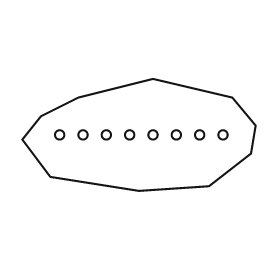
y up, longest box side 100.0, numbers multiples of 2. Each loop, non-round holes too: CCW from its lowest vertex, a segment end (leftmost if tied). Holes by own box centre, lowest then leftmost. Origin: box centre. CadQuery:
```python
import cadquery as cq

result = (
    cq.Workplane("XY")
    .moveTo(0.0, -24.0)
    .lineTo(30.0, -22.0)
    .lineTo(48.0, -8.0)
    .lineTo(50.0, 4.0)
    .lineTo(40.0, 16.0)
    .lineTo(6.0, 24.0)
    .lineTo(-26.0, 16.0)
    .lineTo(-42.0, 8.0)
    .lineTo(-50.0, -2.0)
    .lineTo(-38.0, -18.0)
    .close()
    .moveTo(-34.0, 0.0)
    .circle(2.0)
    .moveTo(-24.0, 0.0)
    .circle(2.0)
    .moveTo(-14.0, 0.0)
    .circle(2.0)
    .moveTo(-4.0, 0.0)
    .circle(2.0)
    .moveTo(6.0, 0.0)
    .circle(2.0)
    .moveTo(16.0, 0.0)
    .circle(2.0)
    .moveTo(26.0, 0.0)
    .circle(2.0)
    .moveTo(36.0, 0.0)
    .circle(2.0)
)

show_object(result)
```